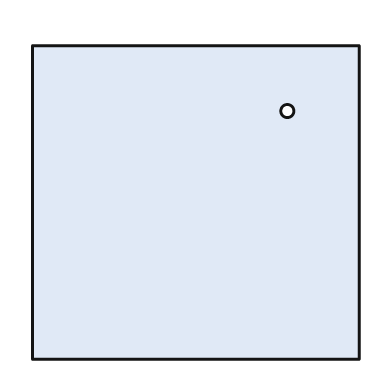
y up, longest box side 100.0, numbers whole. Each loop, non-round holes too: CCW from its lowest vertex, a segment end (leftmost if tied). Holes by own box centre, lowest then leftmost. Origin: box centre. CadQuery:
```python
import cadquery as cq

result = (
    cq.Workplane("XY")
    .moveTo(-50.0, -48.0)
    .lineTo(50.0, -48.0)
    .lineTo(50.0, 48.0)
    .lineTo(-50.0, 48.0)
    .close()
    .moveTo(28.0, 28.0)
    .circle(2.0)
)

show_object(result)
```